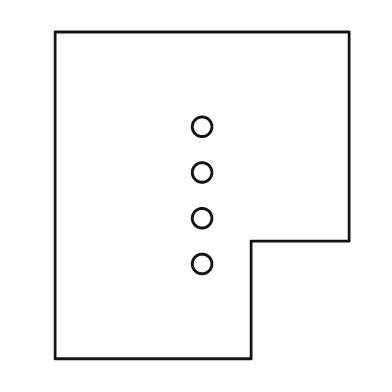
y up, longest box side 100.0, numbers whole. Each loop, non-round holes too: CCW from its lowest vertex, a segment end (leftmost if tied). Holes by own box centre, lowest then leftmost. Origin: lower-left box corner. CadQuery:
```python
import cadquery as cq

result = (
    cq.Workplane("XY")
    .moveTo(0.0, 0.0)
    .lineTo(60.0, 0.0)
    .lineTo(60.0, 36.0)
    .lineTo(90.0, 36.0)
    .lineTo(90.0, 100.0)
    .lineTo(0.0, 100.0)
    .close()
    .moveTo(45.0, 29.0)
    .circle(3.0)
    .moveTo(45.0, 43.0)
    .circle(3.0)
    .moveTo(45.0, 57.0)
    .circle(3.0)
    .moveTo(45.0, 71.0)
    .circle(3.0)
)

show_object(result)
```